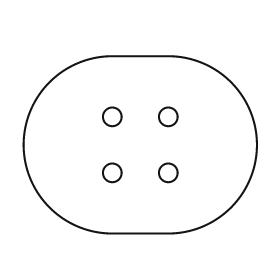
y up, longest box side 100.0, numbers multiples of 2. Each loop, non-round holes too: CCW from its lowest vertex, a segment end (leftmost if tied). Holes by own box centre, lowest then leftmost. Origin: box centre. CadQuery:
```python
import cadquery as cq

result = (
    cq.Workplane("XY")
    .moveTo(-12.0, -38.0)
    .lineTo(12.0, -38.0)
    .threePointArc((50.0, 0.0), (12.0, 38.0))
    .lineTo(-12.0, 38.0)
    .threePointArc((-50.0, 0.0), (-12.0, -38.0))
    .close()
    .moveTo(-12.0, -12.0)
    .circle(4.0)
    .moveTo(12.0, -12.0)
    .circle(4.0)
    .moveTo(-12.0, 12.0)
    .circle(4.0)
    .moveTo(12.0, 12.0)
    .circle(4.0)
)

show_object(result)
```